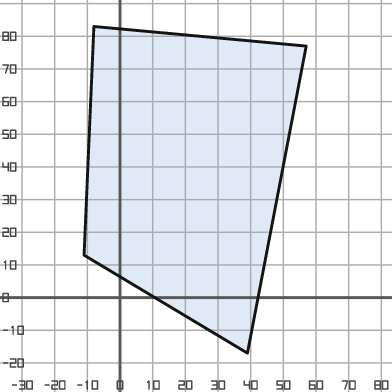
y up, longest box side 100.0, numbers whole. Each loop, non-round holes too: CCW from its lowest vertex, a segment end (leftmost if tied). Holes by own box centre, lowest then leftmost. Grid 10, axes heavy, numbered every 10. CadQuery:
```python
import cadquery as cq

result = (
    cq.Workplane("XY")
    .moveTo(39.0, -17.0)
    .lineTo(57.0, 77.0)
    .lineTo(-8.0, 83.0)
    .lineTo(-11.0, 13.0)
    .close()
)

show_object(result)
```